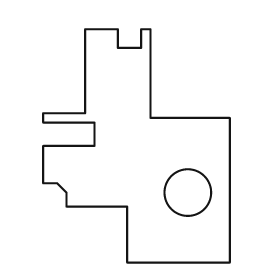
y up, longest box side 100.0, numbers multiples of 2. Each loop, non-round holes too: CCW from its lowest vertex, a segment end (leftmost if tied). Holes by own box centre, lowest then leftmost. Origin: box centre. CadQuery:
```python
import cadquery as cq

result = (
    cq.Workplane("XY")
    .moveTo(-4.0, -50.0)
    .lineTo(40.0, -50.0)
    .lineTo(40.0, 12.0)
    .lineTo(6.0, 12.0)
    .lineTo(6.0, 50.0)
    .lineTo(2.0, 50.0)
    .lineTo(2.0, 42.0)
    .lineTo(-8.0, 42.0)
    .lineTo(-8.0, 50.0)
    .lineTo(-22.0, 50.0)
    .lineTo(-22.0, 14.0)
    .lineTo(-40.0, 14.0)
    .lineTo(-40.0, 10.0)
    .lineTo(-18.0, 10.0)
    .lineTo(-18.0, 0.0)
    .lineTo(-40.0, 0.0)
    .lineTo(-40.0, -16.0)
    .lineTo(-34.0, -16.0)
    .lineTo(-30.0, -20.0)
    .lineTo(-30.0, -26.0)
    .lineTo(-4.0, -26.0)
    .close()
    .moveTo(22.0, -20.0)
    .circle(10.0)
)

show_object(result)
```